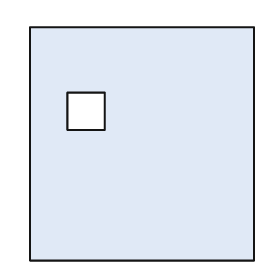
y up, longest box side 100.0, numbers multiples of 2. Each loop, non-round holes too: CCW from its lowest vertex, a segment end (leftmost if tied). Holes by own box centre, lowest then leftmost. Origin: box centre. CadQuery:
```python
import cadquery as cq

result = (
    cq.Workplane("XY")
    .moveTo(-48.0, -50.0)
    .lineTo(48.0, -50.0)
    .lineTo(48.0, 50.0)
    .lineTo(-48.0, 50.0)
    .close()
    .moveTo(-32.0, 6.0)
    .lineTo(-16.0, 6.0)
    .lineTo(-16.0, 22.0)
    .lineTo(-32.0, 22.0)
    .close()
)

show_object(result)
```